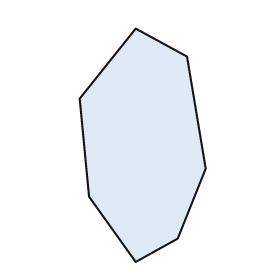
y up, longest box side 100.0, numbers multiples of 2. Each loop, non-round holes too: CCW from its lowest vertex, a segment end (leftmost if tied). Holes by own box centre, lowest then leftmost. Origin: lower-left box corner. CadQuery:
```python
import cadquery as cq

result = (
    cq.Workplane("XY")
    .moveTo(24.0, 0.0)
    .lineTo(42.0, 10.0)
    .lineTo(54.0, 40.0)
    .lineTo(46.0, 88.0)
    .lineTo(24.0, 100.0)
    .lineTo(0.0, 70.0)
    .lineTo(4.0, 28.0)
    .close()
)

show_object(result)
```